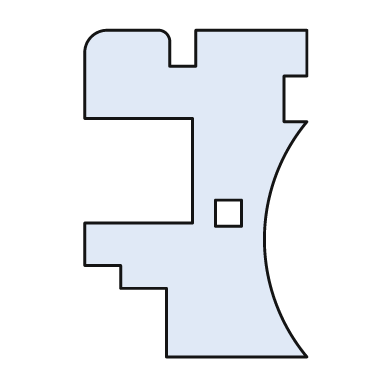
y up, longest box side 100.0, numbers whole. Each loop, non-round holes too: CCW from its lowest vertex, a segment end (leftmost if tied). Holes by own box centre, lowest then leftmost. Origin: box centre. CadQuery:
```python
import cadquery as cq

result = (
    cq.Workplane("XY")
    .moveTo(-9.0, -50.0)
    .lineTo(34.0, -50.0)
    .threePointArc((21.0, -14.0), (34.0, 22.0))
    .lineTo(27.0, 22.0)
    .lineTo(27.0, 36.0)
    .lineTo(34.0, 36.0)
    .lineTo(34.0, 50.0)
    .lineTo(0.0, 50.0)
    .lineTo(0.0, 39.0)
    .lineTo(-8.0, 39.0)
    .lineTo(-8.0, 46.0)
    .threePointArc((-9.0, 49.0), (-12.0, 50.0))
    .lineTo(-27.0, 50.0)
    .threePointArc((-32.0, 48.0), (-34.0, 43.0))
    .lineTo(-34.0, 23.0)
    .lineTo(-1.0, 23.0)
    .lineTo(-1.0, -9.0)
    .lineTo(-34.0, -9.0)
    .lineTo(-34.0, -22.0)
    .lineTo(-23.0, -22.0)
    .lineTo(-23.0, -29.0)
    .lineTo(-9.0, -29.0)
    .close()
    .moveTo(6.0, -10.0)
    .lineTo(14.0, -10.0)
    .lineTo(14.0, -2.0)
    .lineTo(6.0, -2.0)
    .close()
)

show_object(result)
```